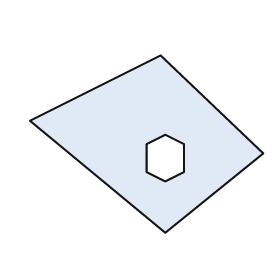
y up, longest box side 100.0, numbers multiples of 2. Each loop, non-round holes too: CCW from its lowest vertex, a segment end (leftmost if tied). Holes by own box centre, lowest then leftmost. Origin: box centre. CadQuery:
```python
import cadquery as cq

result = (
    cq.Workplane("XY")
    .moveTo(8.0, -38.0)
    .lineTo(50.0, -4.0)
    .lineTo(6.0, 38.0)
    .lineTo(-50.0, 10.0)
    .close()
    .moveTo(8.0, -16.0)
    .lineTo(16.0, -12.0)
    .lineTo(16.0, 0.0)
    .lineTo(8.0, 4.0)
    .lineTo(0.0, 0.0)
    .lineTo(0.0, -12.0)
    .close()
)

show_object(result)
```